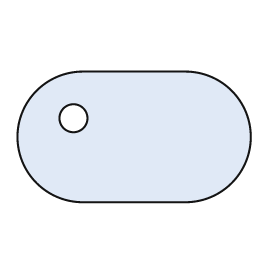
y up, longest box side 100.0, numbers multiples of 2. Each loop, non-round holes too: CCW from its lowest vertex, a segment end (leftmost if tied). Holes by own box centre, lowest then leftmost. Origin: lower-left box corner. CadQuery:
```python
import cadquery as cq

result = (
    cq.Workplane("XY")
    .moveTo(28.0, 0.0)
    .lineTo(72.0, 0.0)
    .threePointArc((100.0, 28.0), (72.0, 56.0))
    .lineTo(28.0, 56.0)
    .threePointArc((0.0, 28.0), (28.0, 0.0))
    .close()
    .moveTo(24.0, 36.0)
    .circle(6.0)
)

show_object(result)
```